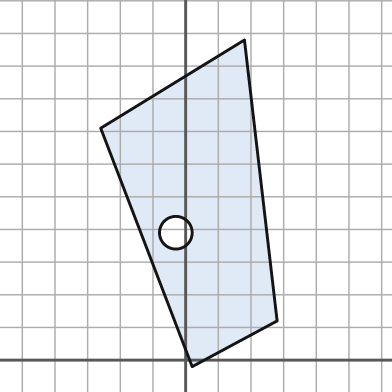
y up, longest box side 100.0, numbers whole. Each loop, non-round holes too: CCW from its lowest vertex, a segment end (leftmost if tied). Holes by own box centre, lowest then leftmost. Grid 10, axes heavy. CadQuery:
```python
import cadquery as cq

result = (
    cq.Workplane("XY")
    .moveTo(2.0, -2.0)
    .lineTo(28.0, 12.0)
    .lineTo(18.0, 98.0)
    .lineTo(-26.0, 71.0)
    .close()
    .moveTo(-3.0, 39.0)
    .circle(5.0)
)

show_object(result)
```